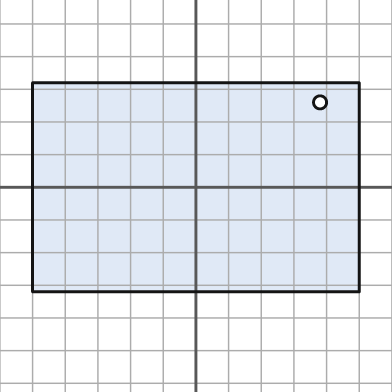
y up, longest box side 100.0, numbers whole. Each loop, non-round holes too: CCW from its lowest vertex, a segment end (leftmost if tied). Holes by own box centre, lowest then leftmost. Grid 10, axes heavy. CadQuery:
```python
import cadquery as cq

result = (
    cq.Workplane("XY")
    .moveTo(-50.0, -32.0)
    .lineTo(50.0, -32.0)
    .lineTo(50.0, 32.0)
    .lineTo(-50.0, 32.0)
    .close()
    .moveTo(38.0, 26.0)
    .circle(2.0)
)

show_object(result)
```